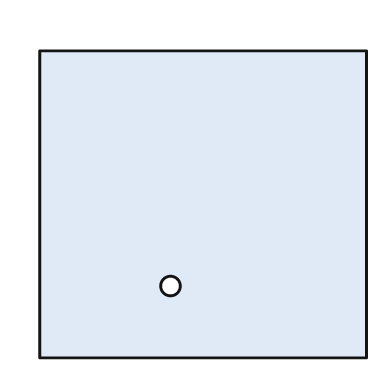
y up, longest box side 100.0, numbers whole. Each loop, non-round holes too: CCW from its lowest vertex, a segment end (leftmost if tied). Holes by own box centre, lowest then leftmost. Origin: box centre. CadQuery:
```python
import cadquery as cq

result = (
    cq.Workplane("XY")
    .moveTo(-50.0, -47.0)
    .lineTo(50.0, -47.0)
    .lineTo(50.0, 47.0)
    .lineTo(-50.0, 47.0)
    .close()
    .moveTo(-10.0, -25.0)
    .circle(3.0)
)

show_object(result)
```